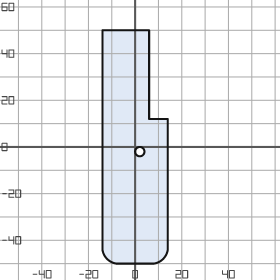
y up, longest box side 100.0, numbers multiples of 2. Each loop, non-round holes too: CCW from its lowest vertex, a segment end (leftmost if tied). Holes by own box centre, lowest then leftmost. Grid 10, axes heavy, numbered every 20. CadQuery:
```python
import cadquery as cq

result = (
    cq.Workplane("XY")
    .moveTo(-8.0, -50.0)
    .lineTo(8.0, -50.0)
    .threePointArc((12.0, -48.0), (14.0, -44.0))
    .lineTo(14.0, 12.0)
    .lineTo(6.0, 12.0)
    .lineTo(6.0, 50.0)
    .lineTo(-14.0, 50.0)
    .lineTo(-14.0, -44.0)
    .threePointArc((-12.0, -48.0), (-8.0, -50.0))
    .close()
    .moveTo(2.0, -2.0)
    .circle(2.0)
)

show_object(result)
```